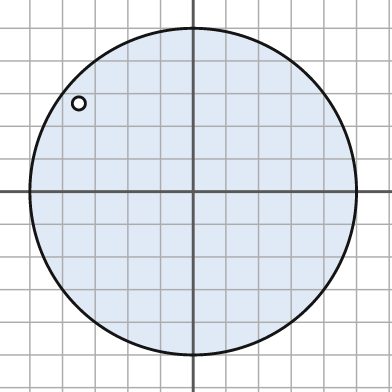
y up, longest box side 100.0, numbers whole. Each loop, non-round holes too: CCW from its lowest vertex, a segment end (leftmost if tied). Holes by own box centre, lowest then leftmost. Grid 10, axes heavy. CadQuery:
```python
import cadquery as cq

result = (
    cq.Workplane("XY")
    .moveTo(0.0, 0.0)
    .circle(50.0)
    .moveTo(-35.0, 27.0)
    .circle(2.0)
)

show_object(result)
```